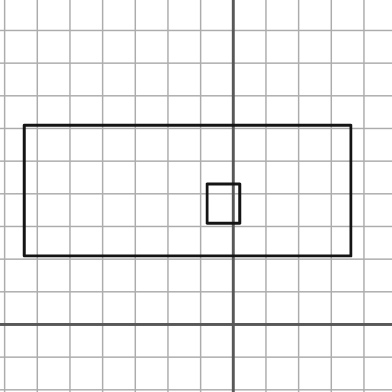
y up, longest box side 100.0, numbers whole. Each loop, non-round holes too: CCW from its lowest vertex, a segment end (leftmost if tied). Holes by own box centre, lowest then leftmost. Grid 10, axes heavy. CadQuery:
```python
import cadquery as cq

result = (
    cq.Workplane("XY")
    .moveTo(-64.0, 21.0)
    .lineTo(36.0, 21.0)
    .lineTo(36.0, 61.0)
    .lineTo(-64.0, 61.0)
    .close()
    .moveTo(-8.0, 31.0)
    .lineTo(2.0, 31.0)
    .lineTo(2.0, 43.0)
    .lineTo(-8.0, 43.0)
    .close()
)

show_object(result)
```